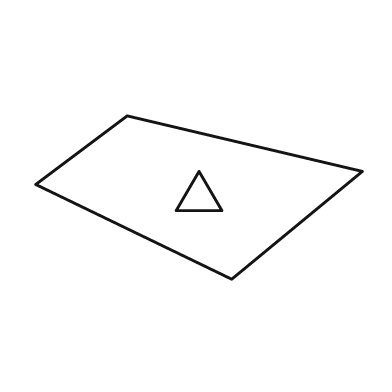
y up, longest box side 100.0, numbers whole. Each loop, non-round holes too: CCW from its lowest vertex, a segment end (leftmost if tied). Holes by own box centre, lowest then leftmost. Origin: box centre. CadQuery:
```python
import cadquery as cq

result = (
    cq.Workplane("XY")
    .moveTo(10.0, -25.0)
    .lineTo(50.0, 8.0)
    .lineTo(-22.0, 25.0)
    .lineTo(-50.0, 4.0)
    .close()
    .moveTo(-7.0, -4.0)
    .lineTo(7.0, -4.0)
    .lineTo(0.0, 8.0)
    .close()
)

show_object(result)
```